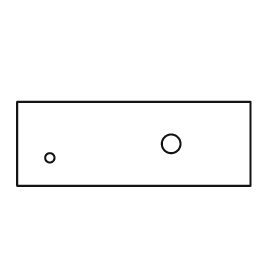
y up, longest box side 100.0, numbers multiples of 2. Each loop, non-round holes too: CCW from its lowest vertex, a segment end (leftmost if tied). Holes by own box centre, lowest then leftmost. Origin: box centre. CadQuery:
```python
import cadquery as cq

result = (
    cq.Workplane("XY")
    .moveTo(-50.0, -18.0)
    .lineTo(50.0, -18.0)
    .lineTo(50.0, 18.0)
    .lineTo(-50.0, 18.0)
    .close()
    .moveTo(-36.0, -6.0)
    .circle(2.0)
    .moveTo(16.0, 0.0)
    .circle(4.0)
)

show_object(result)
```